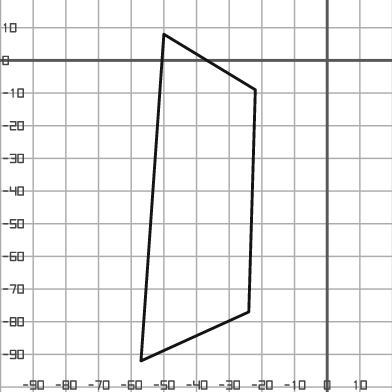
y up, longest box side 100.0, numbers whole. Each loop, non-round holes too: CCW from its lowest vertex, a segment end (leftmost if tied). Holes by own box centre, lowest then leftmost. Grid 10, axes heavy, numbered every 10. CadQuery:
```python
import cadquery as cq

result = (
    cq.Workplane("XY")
    .moveTo(-57.0, -92.0)
    .lineTo(-24.0, -77.0)
    .lineTo(-22.0, -9.0)
    .lineTo(-50.0, 8.0)
    .close()
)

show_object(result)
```